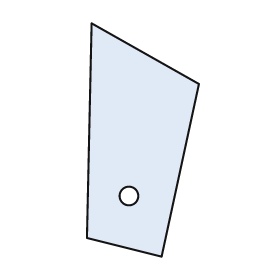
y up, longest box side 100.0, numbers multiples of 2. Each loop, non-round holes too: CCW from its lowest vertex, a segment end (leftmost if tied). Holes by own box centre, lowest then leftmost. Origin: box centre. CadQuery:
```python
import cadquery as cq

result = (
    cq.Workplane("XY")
    .moveTo(8.0, -50.0)
    .lineTo(24.0, 24.0)
    .lineTo(-22.0, 50.0)
    .lineTo(-24.0, -42.0)
    .close()
    .moveTo(-6.0, -24.0)
    .circle(4.0)
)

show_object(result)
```